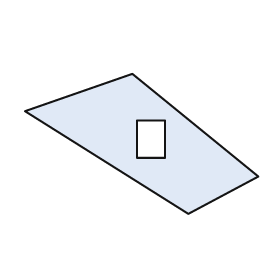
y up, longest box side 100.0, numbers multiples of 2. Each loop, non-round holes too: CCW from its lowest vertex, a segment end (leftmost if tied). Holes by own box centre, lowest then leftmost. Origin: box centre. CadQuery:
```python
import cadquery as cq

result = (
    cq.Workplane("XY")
    .moveTo(20.0, -30.0)
    .lineTo(50.0, -14.0)
    .lineTo(-4.0, 30.0)
    .lineTo(-50.0, 14.0)
    .close()
    .moveTo(-2.0, -6.0)
    .lineTo(10.0, -6.0)
    .lineTo(10.0, 10.0)
    .lineTo(-2.0, 10.0)
    .close()
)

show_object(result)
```